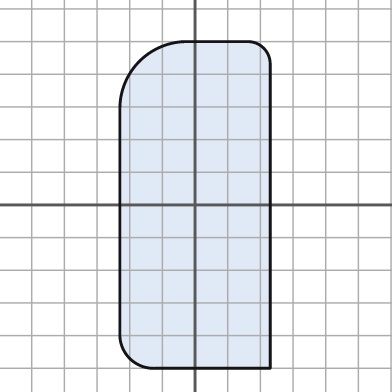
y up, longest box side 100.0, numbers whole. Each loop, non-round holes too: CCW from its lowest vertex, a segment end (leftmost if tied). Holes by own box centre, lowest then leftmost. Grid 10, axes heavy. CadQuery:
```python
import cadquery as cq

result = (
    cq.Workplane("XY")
    .moveTo(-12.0, -50.0)
    .lineTo(23.0, -50.0)
    .lineTo(23.0, 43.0)
    .threePointArc((21.0, 48.0), (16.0, 50.0))
    .lineTo(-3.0, 50.0)
    .threePointArc((-17.0, 44.0), (-23.0, 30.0))
    .lineTo(-23.0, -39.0)
    .threePointArc((-20.0, -47.0), (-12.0, -50.0))
    .close()
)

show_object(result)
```